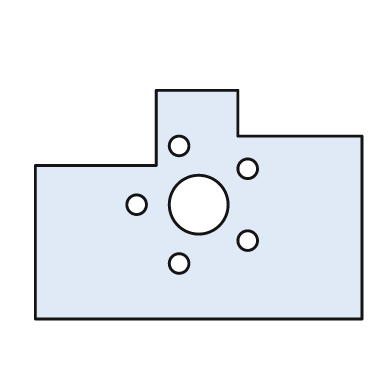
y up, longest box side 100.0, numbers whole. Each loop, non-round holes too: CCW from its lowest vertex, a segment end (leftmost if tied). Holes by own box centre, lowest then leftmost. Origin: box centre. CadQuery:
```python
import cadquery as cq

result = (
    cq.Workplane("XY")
    .moveTo(-50.0, -35.0)
    .lineTo(50.0, -35.0)
    .lineTo(50.0, 21.0)
    .lineTo(12.0, 21.0)
    .lineTo(12.0, 35.0)
    .lineTo(-13.0, 35.0)
    .lineTo(-13.0, 12.0)
    .lineTo(-50.0, 12.0)
    .close()
    .moveTo(-6.0, -18.0)
    .circle(3.0)
    .moveTo(15.0, -11.0)
    .circle(3.0)
    .moveTo(-19.0, 0.0)
    .circle(3.0)
    .moveTo(0.0, 0.0)
    .circle(9.0)
    .moveTo(15.0, 11.0)
    .circle(3.0)
    .moveTo(-6.0, 18.0)
    .circle(3.0)
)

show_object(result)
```